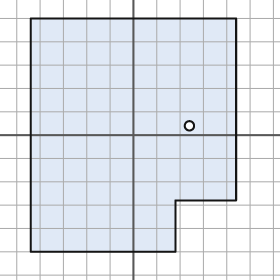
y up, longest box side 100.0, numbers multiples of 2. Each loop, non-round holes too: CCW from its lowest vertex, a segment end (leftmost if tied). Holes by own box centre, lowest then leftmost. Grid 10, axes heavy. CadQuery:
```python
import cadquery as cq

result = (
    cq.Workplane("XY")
    .moveTo(-44.0, -50.0)
    .lineTo(18.0, -50.0)
    .lineTo(18.0, -28.0)
    .lineTo(44.0, -28.0)
    .lineTo(44.0, 50.0)
    .lineTo(-44.0, 50.0)
    .close()
    .moveTo(24.0, 4.0)
    .circle(2.0)
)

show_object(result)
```